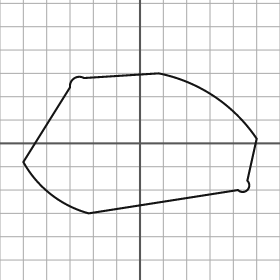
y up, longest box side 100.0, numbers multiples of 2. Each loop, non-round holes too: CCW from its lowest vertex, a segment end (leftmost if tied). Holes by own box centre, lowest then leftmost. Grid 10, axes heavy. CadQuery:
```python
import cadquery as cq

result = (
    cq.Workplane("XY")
    .moveTo(-22.0, -30.0)
    .lineTo(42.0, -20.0)
    .threePointArc((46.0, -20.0), (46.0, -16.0))
    .lineTo(50.0, 2.0)
    .threePointArc((32.0, 20.0), (8.0, 30.0))
    .lineTo(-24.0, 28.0)
    .threePointArc((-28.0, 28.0), (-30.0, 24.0))
    .lineTo(-50.0, -8.0)
    .threePointArc((-38.0, -22.0), (-22.0, -30.0))
    .close()
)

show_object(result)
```